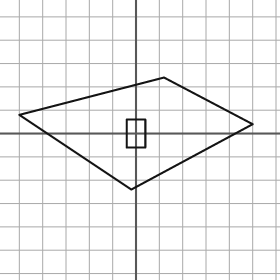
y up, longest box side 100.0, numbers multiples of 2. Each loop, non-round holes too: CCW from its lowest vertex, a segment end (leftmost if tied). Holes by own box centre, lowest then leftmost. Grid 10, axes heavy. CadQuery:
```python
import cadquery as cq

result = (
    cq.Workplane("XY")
    .moveTo(-2.0, -24.0)
    .lineTo(50.0, 4.0)
    .lineTo(12.0, 24.0)
    .lineTo(-50.0, 8.0)
    .close()
    .moveTo(-4.0, -6.0)
    .lineTo(4.0, -6.0)
    .lineTo(4.0, 6.0)
    .lineTo(-4.0, 6.0)
    .close()
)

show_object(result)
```